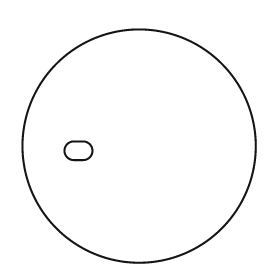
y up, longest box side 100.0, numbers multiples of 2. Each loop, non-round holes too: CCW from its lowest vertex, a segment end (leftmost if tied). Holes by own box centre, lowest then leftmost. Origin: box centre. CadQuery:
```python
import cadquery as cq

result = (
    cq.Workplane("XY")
    .moveTo(0.0, 0.0)
    .circle(50.0)
    .moveTo(-28.0, -6.0)
    .lineTo(-24.0, -6.0)
    .threePointArc((-20.0, -2.0), (-24.0, 2.0))
    .lineTo(-28.0, 2.0)
    .threePointArc((-32.0, -2.0), (-28.0, -6.0))
    .close()
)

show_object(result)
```